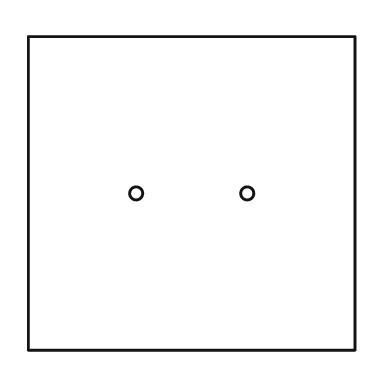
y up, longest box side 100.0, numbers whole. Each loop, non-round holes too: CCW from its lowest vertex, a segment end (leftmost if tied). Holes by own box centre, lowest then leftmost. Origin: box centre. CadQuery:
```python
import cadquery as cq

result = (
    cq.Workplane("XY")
    .moveTo(-50.0, -48.0)
    .lineTo(50.0, -48.0)
    .lineTo(50.0, 48.0)
    .lineTo(-50.0, 48.0)
    .close()
    .moveTo(-17.0, 0.0)
    .circle(2.0)
    .moveTo(17.0, 0.0)
    .circle(2.0)
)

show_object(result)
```